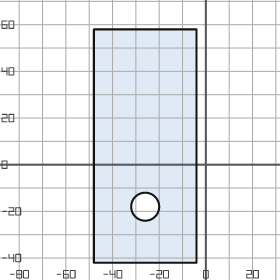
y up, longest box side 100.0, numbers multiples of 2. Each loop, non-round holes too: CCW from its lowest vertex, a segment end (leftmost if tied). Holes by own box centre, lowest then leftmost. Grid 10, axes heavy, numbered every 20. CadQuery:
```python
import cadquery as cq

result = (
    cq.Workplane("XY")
    .moveTo(-48.0, -42.0)
    .lineTo(-4.0, -42.0)
    .lineTo(-4.0, 58.0)
    .lineTo(-48.0, 58.0)
    .close()
    .moveTo(-26.0, -18.0)
    .circle(6.0)
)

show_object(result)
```